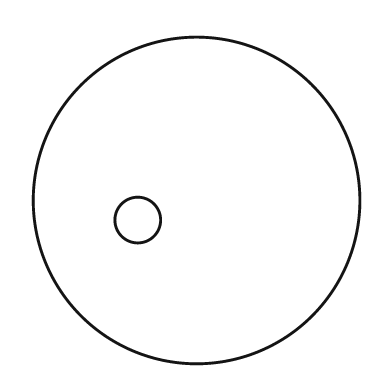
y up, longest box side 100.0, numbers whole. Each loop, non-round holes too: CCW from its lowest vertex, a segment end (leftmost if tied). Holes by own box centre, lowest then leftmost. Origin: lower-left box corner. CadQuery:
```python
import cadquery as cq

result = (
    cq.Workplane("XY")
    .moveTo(50.0, 50.0)
    .circle(50.0)
    .moveTo(32.0, 44.0)
    .circle(7.0)
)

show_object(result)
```